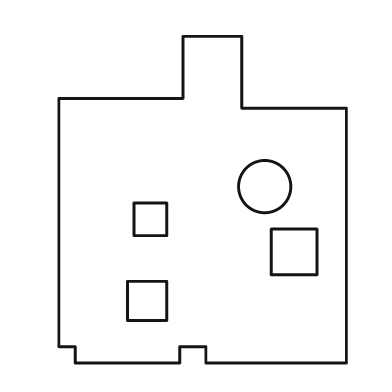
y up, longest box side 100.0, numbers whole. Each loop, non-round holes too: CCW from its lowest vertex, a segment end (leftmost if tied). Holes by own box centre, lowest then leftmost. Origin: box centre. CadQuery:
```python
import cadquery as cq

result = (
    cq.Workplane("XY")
    .moveTo(-39.0, -50.0)
    .lineTo(-7.0, -50.0)
    .lineTo(-7.0, -45.0)
    .lineTo(1.0, -45.0)
    .lineTo(1.0, -50.0)
    .lineTo(44.0, -50.0)
    .lineTo(44.0, 28.0)
    .lineTo(12.0, 28.0)
    .lineTo(12.0, 50.0)
    .lineTo(-6.0, 50.0)
    .lineTo(-6.0, 31.0)
    .lineTo(-44.0, 31.0)
    .lineTo(-44.0, -45.0)
    .lineTo(-39.0, -45.0)
    .close()
    .moveTo(-23.0, -37.0)
    .lineTo(-11.0, -37.0)
    .lineTo(-11.0, -25.0)
    .lineTo(-23.0, -25.0)
    .close()
    .moveTo(21.0, -23.0)
    .lineTo(35.0, -23.0)
    .lineTo(35.0, -9.0)
    .lineTo(21.0, -9.0)
    .close()
    .moveTo(-21.0, -11.0)
    .lineTo(-11.0, -11.0)
    .lineTo(-11.0, -1.0)
    .lineTo(-21.0, -1.0)
    .close()
    .moveTo(19.0, 4.0)
    .circle(8.0)
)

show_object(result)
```